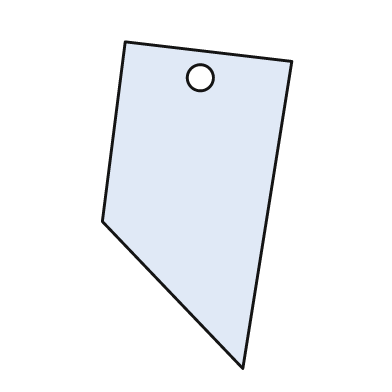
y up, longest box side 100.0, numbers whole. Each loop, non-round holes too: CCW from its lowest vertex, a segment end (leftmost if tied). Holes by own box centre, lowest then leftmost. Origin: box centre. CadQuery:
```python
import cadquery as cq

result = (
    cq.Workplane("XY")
    .moveTo(14.0, -50.0)
    .lineTo(29.0, 44.0)
    .lineTo(-22.0, 50.0)
    .lineTo(-29.0, -5.0)
    .close()
    .moveTo(1.0, 39.0)
    .circle(4.0)
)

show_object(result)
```